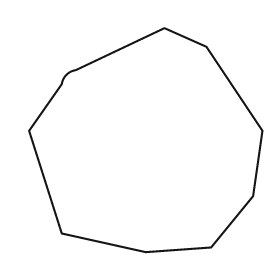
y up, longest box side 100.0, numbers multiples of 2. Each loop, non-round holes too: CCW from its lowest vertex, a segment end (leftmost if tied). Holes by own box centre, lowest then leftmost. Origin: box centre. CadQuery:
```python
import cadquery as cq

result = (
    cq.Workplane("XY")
    .moveTo(0.0, -48.0)
    .lineTo(28.0, -46.0)
    .lineTo(46.0, -24.0)
    .lineTo(50.0, 4.0)
    .lineTo(26.0, 40.0)
    .lineTo(8.0, 48.0)
    .lineTo(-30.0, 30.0)
    .threePointArc((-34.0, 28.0), (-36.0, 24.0))
    .lineTo(-50.0, 4.0)
    .lineTo(-36.0, -40.0)
    .close()
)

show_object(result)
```